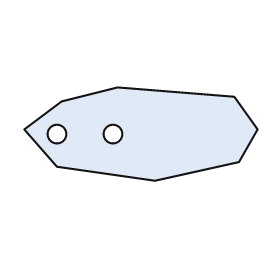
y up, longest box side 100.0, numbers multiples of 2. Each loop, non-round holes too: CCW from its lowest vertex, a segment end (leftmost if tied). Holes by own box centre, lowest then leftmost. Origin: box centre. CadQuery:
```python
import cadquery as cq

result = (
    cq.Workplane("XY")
    .moveTo(6.0, -20.0)
    .lineTo(42.0, -12.0)
    .lineTo(50.0, 2.0)
    .lineTo(40.0, 16.0)
    .lineTo(-10.0, 20.0)
    .lineTo(-34.0, 14.0)
    .lineTo(-50.0, 2.0)
    .lineTo(-36.0, -14.0)
    .close()
    .moveTo(-36.0, 0.0)
    .circle(4.0)
    .moveTo(-12.0, 0.0)
    .circle(4.0)
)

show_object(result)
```